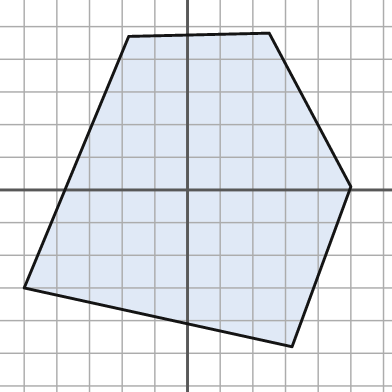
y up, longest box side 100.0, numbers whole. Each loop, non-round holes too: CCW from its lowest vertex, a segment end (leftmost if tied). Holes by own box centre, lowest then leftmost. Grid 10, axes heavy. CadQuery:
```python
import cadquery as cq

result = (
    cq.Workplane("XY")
    .moveTo(32.0, -48.0)
    .lineTo(50.0, 1.0)
    .lineTo(25.0, 48.0)
    .lineTo(-18.0, 47.0)
    .lineTo(-50.0, -30.0)
    .close()
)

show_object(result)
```